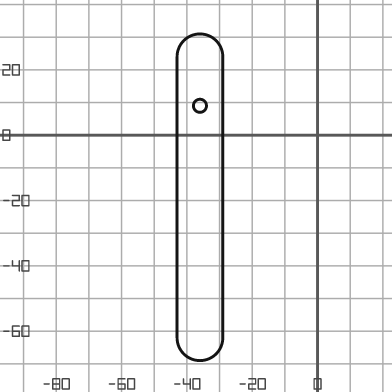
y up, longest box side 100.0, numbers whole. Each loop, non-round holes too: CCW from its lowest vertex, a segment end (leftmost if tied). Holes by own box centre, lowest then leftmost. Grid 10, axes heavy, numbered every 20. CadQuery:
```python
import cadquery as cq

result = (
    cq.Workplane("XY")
    .moveTo(-43.0, -62.0)
    .threePointArc((-36.0, -69.0), (-29.0, -62.0))
    .lineTo(-29.0, 24.0)
    .threePointArc((-36.0, 31.0), (-43.0, 24.0))
    .close()
    .moveTo(-36.0, 9.0)
    .circle(2.0)
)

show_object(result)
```